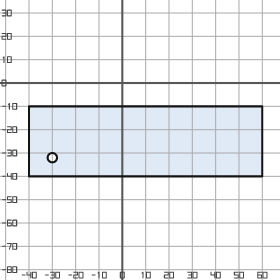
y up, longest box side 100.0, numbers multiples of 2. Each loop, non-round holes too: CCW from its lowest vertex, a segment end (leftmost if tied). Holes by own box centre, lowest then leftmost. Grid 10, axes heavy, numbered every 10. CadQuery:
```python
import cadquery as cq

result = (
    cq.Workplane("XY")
    .moveTo(-40.0, -40.0)
    .lineTo(60.0, -40.0)
    .lineTo(60.0, -10.0)
    .lineTo(-40.0, -10.0)
    .close()
    .moveTo(-30.0, -32.0)
    .circle(2.0)
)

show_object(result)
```